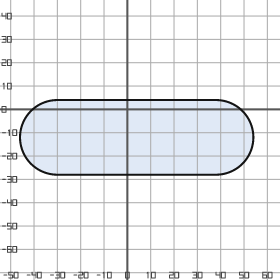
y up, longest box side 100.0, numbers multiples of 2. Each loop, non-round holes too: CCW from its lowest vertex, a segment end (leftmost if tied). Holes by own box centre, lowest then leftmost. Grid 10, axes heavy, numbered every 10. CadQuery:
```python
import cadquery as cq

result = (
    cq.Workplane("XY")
    .moveTo(-30.0, -28.0)
    .lineTo(38.0, -28.0)
    .threePointArc((54.0, -12.0), (38.0, 4.0))
    .lineTo(-30.0, 4.0)
    .threePointArc((-46.0, -12.0), (-30.0, -28.0))
    .close()
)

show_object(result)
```